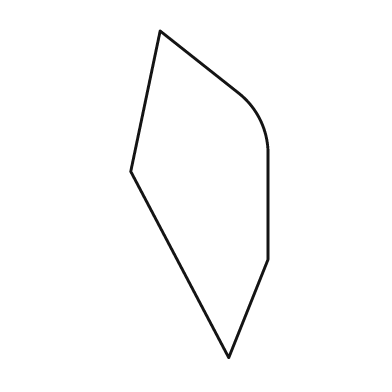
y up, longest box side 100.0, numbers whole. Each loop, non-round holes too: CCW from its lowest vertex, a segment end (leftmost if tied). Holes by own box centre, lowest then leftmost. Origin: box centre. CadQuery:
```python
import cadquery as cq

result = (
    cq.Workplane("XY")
    .moveTo(9.0, -50.0)
    .lineTo(21.0, -20.0)
    .lineTo(21.0, 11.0)
    .threePointArc((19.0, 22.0), (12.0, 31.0))
    .lineTo(-12.0, 50.0)
    .lineTo(-21.0, 7.0)
    .close()
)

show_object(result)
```